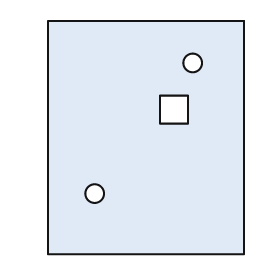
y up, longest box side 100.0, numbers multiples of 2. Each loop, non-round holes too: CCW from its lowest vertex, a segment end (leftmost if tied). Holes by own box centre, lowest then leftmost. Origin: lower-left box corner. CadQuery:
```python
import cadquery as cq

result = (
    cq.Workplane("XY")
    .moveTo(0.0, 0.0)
    .lineTo(84.0, 0.0)
    .lineTo(84.0, 100.0)
    .lineTo(0.0, 100.0)
    .close()
    .moveTo(20.0, 26.0)
    .circle(4.0)
    .moveTo(48.0, 56.0)
    .lineTo(60.0, 56.0)
    .lineTo(60.0, 68.0)
    .lineTo(48.0, 68.0)
    .close()
    .moveTo(62.0, 82.0)
    .circle(4.0)
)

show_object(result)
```